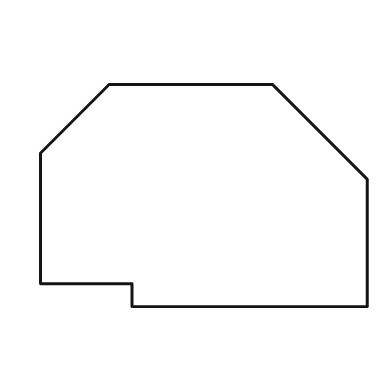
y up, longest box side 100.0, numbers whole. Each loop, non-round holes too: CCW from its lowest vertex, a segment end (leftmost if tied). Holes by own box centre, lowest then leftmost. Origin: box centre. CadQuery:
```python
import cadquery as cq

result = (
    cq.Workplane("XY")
    .moveTo(-22.0, -34.0)
    .lineTo(50.0, -34.0)
    .lineTo(50.0, 5.0)
    .lineTo(21.0, 34.0)
    .lineTo(-29.0, 34.0)
    .lineTo(-50.0, 13.0)
    .lineTo(-50.0, -27.0)
    .lineTo(-22.0, -27.0)
    .close()
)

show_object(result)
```